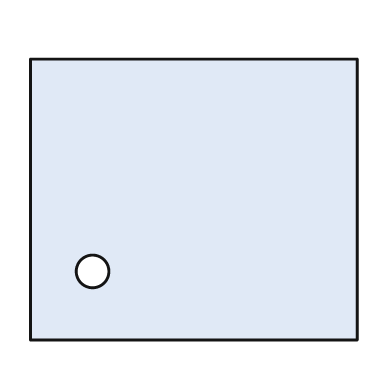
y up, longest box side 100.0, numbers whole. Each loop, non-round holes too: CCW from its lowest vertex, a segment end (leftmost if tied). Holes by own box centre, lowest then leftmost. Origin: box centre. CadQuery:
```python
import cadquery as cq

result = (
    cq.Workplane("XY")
    .moveTo(-50.0, -43.0)
    .lineTo(50.0, -43.0)
    .lineTo(50.0, 43.0)
    .lineTo(-50.0, 43.0)
    .close()
    .moveTo(-31.0, -22.0)
    .circle(5.0)
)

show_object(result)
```